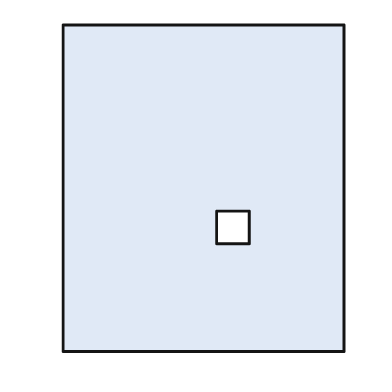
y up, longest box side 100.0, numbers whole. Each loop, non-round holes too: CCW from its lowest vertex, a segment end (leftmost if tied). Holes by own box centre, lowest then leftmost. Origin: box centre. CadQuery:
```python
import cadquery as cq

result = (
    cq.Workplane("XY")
    .moveTo(-43.0, -50.0)
    .lineTo(43.0, -50.0)
    .lineTo(43.0, 50.0)
    .lineTo(-43.0, 50.0)
    .close()
    .moveTo(4.0, -17.0)
    .lineTo(14.0, -17.0)
    .lineTo(14.0, -7.0)
    .lineTo(4.0, -7.0)
    .close()
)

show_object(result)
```